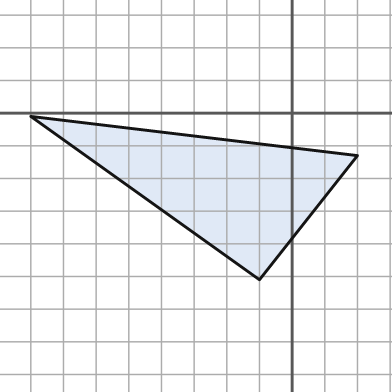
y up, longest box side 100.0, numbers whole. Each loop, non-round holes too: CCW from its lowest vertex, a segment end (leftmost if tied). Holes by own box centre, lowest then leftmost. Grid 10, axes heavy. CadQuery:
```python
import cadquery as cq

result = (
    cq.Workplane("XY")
    .moveTo(-10.0, -51.0)
    .lineTo(20.0, -13.0)
    .lineTo(-80.0, -1.0)
    .close()
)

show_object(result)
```